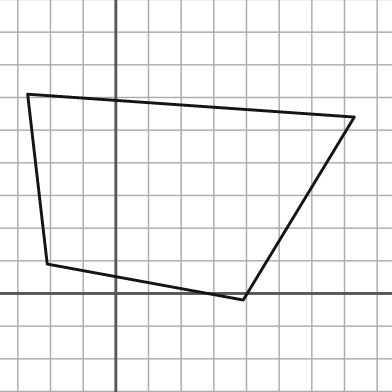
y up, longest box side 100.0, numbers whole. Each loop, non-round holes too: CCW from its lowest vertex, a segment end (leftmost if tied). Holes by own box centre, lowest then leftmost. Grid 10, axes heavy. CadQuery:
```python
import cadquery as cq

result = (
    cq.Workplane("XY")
    .moveTo(39.0, -2.0)
    .lineTo(73.0, 54.0)
    .lineTo(-27.0, 61.0)
    .lineTo(-21.0, 9.0)
    .close()
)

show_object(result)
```